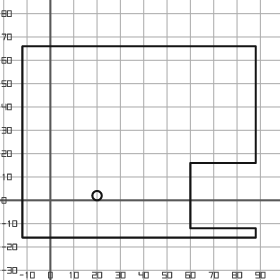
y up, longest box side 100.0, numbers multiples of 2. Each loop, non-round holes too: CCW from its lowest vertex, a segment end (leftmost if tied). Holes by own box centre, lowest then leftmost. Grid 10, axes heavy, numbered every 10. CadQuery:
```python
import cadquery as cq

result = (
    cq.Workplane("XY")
    .moveTo(-12.0, -16.0)
    .lineTo(88.0, -16.0)
    .lineTo(88.0, -12.0)
    .lineTo(60.0, -12.0)
    .lineTo(60.0, 16.0)
    .lineTo(88.0, 16.0)
    .lineTo(88.0, 66.0)
    .lineTo(-12.0, 66.0)
    .close()
    .moveTo(20.0, 2.0)
    .circle(2.0)
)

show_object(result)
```